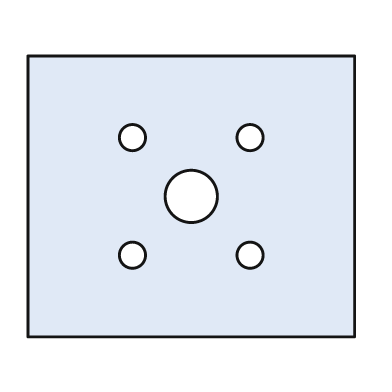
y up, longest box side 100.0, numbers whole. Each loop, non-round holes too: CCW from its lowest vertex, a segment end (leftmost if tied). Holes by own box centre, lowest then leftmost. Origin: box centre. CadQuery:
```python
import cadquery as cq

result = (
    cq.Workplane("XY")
    .moveTo(-50.0, -43.0)
    .lineTo(50.0, -43.0)
    .lineTo(50.0, 43.0)
    .lineTo(-50.0, 43.0)
    .close()
    .moveTo(-18.0, -18.0)
    .circle(4.0)
    .moveTo(18.0, -18.0)
    .circle(4.0)
    .moveTo(0.0, 0.0)
    .circle(8.0)
    .moveTo(-18.0, 18.0)
    .circle(4.0)
    .moveTo(18.0, 18.0)
    .circle(4.0)
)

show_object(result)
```